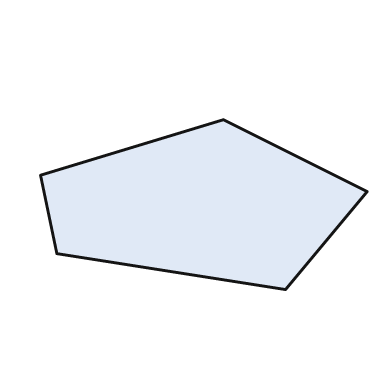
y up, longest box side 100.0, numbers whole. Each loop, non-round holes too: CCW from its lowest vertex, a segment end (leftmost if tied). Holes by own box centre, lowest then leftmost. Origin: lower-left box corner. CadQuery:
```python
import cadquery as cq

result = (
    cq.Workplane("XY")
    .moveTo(75.0, 0.0)
    .lineTo(100.0, 30.0)
    .lineTo(56.0, 52.0)
    .lineTo(0.0, 35.0)
    .lineTo(5.0, 11.0)
    .close()
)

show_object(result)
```